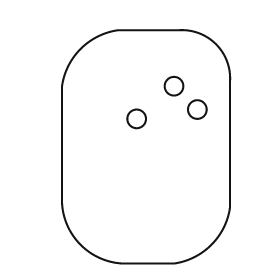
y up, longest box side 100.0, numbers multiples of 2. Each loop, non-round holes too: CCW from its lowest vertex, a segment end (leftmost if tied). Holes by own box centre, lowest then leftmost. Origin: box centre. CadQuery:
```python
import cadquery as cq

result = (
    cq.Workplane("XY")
    .moveTo(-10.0, -50.0)
    .lineTo(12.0, -50.0)
    .threePointArc((28.0, -42.0), (36.0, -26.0))
    .lineTo(36.0, 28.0)
    .threePointArc((30.0, 44.0), (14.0, 50.0))
    .lineTo(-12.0, 50.0)
    .threePointArc((-28.0, 42.0), (-36.0, 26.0))
    .lineTo(-36.0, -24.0)
    .threePointArc((-28.0, -42.0), (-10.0, -50.0))
    .close()
    .moveTo(-4.0, 12.0)
    .circle(4.0)
    .moveTo(22.0, 16.0)
    .circle(4.0)
    .moveTo(12.0, 26.0)
    .circle(4.0)
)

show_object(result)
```